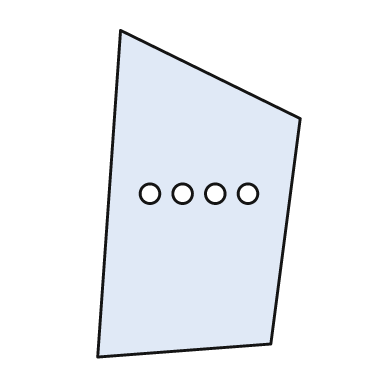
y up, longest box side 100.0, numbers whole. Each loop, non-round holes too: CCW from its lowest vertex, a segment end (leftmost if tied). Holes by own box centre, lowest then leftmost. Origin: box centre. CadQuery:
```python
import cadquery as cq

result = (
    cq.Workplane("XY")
    .moveTo(-31.0, -50.0)
    .lineTo(22.0, -46.0)
    .lineTo(31.0, 23.0)
    .lineTo(-24.0, 50.0)
    .close()
    .moveTo(-15.0, 0.0)
    .circle(3.0)
    .moveTo(-5.0, 0.0)
    .circle(3.0)
    .moveTo(5.0, 0.0)
    .circle(3.0)
    .moveTo(15.0, 0.0)
    .circle(3.0)
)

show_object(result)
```